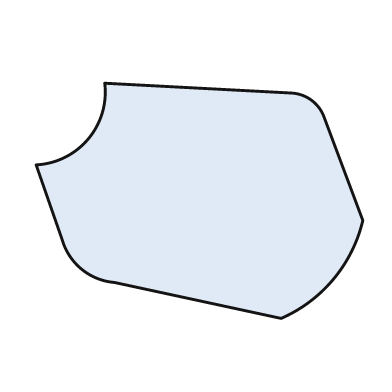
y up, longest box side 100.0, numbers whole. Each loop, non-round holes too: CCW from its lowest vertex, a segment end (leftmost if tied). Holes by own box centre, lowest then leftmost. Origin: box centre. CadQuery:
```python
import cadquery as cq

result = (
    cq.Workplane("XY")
    .moveTo(25.0, -36.0)
    .threePointArc((41.0, -24.0), (50.0, -6.0))
    .lineTo(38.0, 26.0)
    .threePointArc((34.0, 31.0), (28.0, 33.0))
    .lineTo(-29.0, 36.0)
    .threePointArc((-34.0, 19.0), (-50.0, 11.0))
    .lineTo(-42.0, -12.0)
    .threePointArc((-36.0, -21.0), (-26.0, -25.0))
    .close()
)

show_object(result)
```